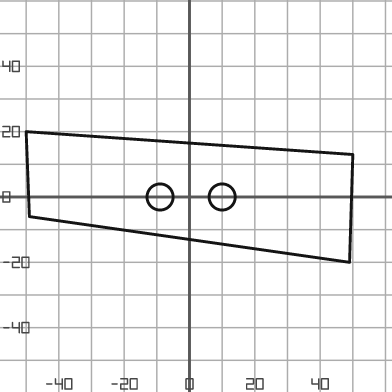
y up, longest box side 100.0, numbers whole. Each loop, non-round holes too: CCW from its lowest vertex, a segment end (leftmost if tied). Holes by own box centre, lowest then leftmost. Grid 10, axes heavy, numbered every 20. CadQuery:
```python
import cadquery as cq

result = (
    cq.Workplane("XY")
    .moveTo(49.0, -20.0)
    .lineTo(50.0, 13.0)
    .lineTo(-50.0, 20.0)
    .lineTo(-49.0, -6.0)
    .close()
    .moveTo(-9.0, 0.0)
    .circle(4.0)
    .moveTo(10.0, 0.0)
    .circle(4.0)
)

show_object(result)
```